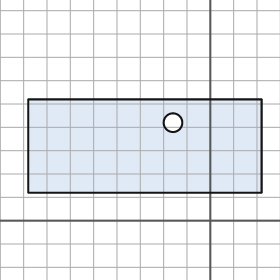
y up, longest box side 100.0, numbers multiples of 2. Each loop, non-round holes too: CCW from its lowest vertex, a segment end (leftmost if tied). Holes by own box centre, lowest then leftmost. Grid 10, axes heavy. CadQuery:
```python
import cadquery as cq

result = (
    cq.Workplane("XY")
    .moveTo(-78.0, 12.0)
    .lineTo(22.0, 12.0)
    .lineTo(22.0, 52.0)
    .lineTo(-78.0, 52.0)
    .close()
    .moveTo(-16.0, 42.0)
    .circle(4.0)
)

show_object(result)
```